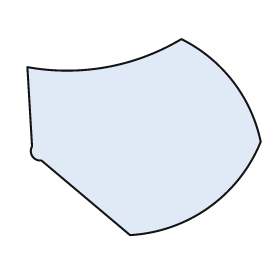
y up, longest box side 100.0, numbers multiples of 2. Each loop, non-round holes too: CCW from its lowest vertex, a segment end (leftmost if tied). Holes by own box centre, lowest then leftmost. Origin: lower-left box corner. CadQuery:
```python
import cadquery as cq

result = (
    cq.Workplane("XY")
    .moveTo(44.0, 0.0)
    .threePointArc((78.0, 12.0), (100.0, 40.0))
    .threePointArc((88.0, 66.0), (66.0, 84.0))
    .threePointArc((34.0, 72.0), (0.0, 72.0))
    .lineTo(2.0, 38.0)
    .threePointArc((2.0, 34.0), (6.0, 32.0))
    .close()
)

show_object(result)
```